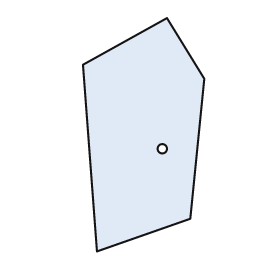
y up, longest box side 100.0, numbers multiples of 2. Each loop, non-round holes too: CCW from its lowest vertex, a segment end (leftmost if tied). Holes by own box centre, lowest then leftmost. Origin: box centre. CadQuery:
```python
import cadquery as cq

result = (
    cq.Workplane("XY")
    .moveTo(-20.0, -50.0)
    .lineTo(20.0, -36.0)
    .lineTo(26.0, 24.0)
    .lineTo(10.0, 50.0)
    .lineTo(-26.0, 30.0)
    .close()
    .moveTo(8.0, -6.0)
    .circle(2.0)
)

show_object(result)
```